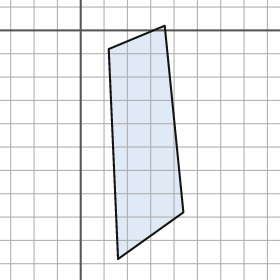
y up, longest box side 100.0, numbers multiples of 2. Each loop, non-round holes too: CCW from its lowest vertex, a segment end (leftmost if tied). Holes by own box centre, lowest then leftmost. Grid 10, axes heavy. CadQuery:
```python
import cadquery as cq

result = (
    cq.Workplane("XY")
    .moveTo(16.0, -98.0)
    .lineTo(44.0, -78.0)
    .lineTo(36.0, 2.0)
    .lineTo(12.0, -8.0)
    .close()
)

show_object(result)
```